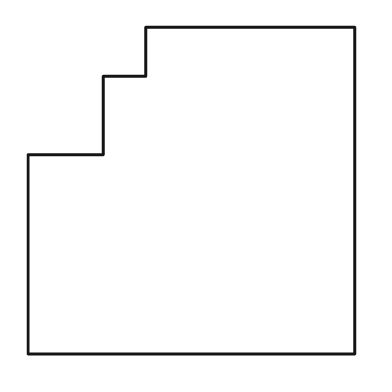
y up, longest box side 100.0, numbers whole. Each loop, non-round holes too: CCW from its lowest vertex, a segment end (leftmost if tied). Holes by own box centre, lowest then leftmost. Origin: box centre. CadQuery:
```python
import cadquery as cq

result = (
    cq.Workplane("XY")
    .moveTo(-50.0, -50.0)
    .lineTo(50.0, -50.0)
    .lineTo(50.0, 50.0)
    .lineTo(-14.0, 50.0)
    .lineTo(-14.0, 35.0)
    .lineTo(-27.0, 35.0)
    .lineTo(-27.0, 11.0)
    .lineTo(-50.0, 11.0)
    .close()
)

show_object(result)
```